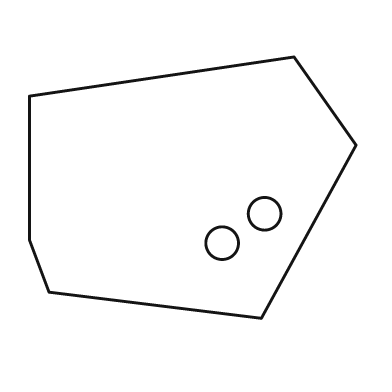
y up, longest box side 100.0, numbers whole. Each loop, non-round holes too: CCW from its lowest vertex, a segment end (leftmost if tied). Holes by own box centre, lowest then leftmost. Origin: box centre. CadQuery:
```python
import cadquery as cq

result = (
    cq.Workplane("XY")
    .moveTo(21.0, -40.0)
    .lineTo(50.0, 13.0)
    .lineTo(31.0, 40.0)
    .lineTo(-50.0, 28.0)
    .lineTo(-50.0, -16.0)
    .lineTo(-44.0, -32.0)
    .close()
    .moveTo(9.0, -17.0)
    .circle(5.0)
    .moveTo(22.0, -8.0)
    .circle(5.0)
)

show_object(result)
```